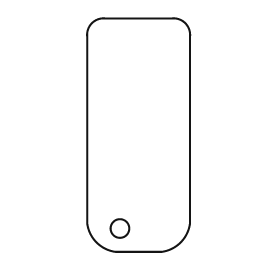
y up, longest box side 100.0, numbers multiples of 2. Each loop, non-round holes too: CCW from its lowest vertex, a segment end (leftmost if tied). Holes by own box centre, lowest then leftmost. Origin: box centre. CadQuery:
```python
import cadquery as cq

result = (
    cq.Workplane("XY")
    .moveTo(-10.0, -50.0)
    .lineTo(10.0, -50.0)
    .threePointArc((18.0, -46.0), (22.0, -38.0))
    .lineTo(22.0, 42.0)
    .threePointArc((20.0, 48.0), (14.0, 50.0))
    .lineTo(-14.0, 50.0)
    .threePointArc((-20.0, 48.0), (-22.0, 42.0))
    .lineTo(-22.0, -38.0)
    .threePointArc((-18.0, -46.0), (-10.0, -50.0))
    .close()
    .moveTo(-8.0, -40.0)
    .circle(4.0)
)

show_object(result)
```